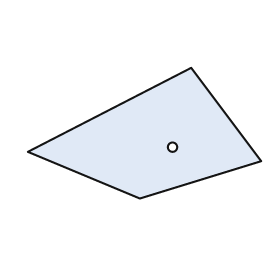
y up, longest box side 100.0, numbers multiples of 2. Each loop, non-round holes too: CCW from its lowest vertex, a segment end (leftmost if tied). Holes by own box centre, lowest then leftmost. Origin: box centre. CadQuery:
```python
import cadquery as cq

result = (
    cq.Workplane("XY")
    .moveTo(-2.0, -28.0)
    .lineTo(50.0, -12.0)
    .lineTo(20.0, 28.0)
    .lineTo(-50.0, -8.0)
    .close()
    .moveTo(12.0, -6.0)
    .circle(2.0)
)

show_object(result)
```